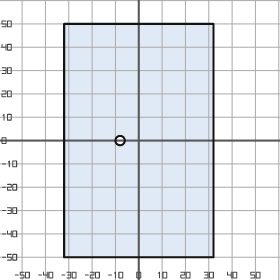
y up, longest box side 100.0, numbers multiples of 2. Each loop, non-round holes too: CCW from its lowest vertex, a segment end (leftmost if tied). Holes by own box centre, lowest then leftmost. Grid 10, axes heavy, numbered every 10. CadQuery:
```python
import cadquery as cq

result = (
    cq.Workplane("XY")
    .moveTo(-32.0, -50.0)
    .lineTo(32.0, -50.0)
    .lineTo(32.0, 50.0)
    .lineTo(-32.0, 50.0)
    .close()
    .moveTo(-8.0, 0.0)
    .circle(2.0)
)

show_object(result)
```